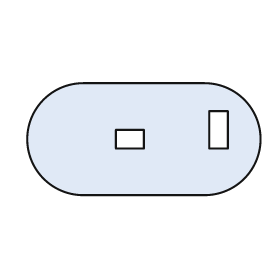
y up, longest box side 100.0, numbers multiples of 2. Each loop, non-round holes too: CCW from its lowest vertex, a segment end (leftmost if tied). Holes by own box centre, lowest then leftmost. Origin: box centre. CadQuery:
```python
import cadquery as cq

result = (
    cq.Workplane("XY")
    .moveTo(-26.0, -24.0)
    .lineTo(26.0, -24.0)
    .threePointArc((50.0, 0.0), (26.0, 24.0))
    .lineTo(-26.0, 24.0)
    .threePointArc((-50.0, 0.0), (-26.0, -24.0))
    .close()
    .moveTo(-12.0, -4.0)
    .lineTo(0.0, -4.0)
    .lineTo(0.0, 4.0)
    .lineTo(-12.0, 4.0)
    .close()
    .moveTo(28.0, -4.0)
    .lineTo(36.0, -4.0)
    .lineTo(36.0, 12.0)
    .lineTo(28.0, 12.0)
    .close()
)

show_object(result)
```